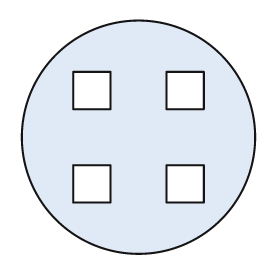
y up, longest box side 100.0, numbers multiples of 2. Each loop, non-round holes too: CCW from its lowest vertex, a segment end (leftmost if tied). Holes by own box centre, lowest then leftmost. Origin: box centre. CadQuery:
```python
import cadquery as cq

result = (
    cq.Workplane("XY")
    .moveTo(0.0, 0.0)
    .circle(50.0)
    .moveTo(-28.0, -28.0)
    .lineTo(-12.0, -28.0)
    .lineTo(-12.0, -12.0)
    .lineTo(-28.0, -12.0)
    .close()
    .moveTo(12.0, -28.0)
    .lineTo(28.0, -28.0)
    .lineTo(28.0, -12.0)
    .lineTo(12.0, -12.0)
    .close()
    .moveTo(-28.0, 12.0)
    .lineTo(-12.0, 12.0)
    .lineTo(-12.0, 28.0)
    .lineTo(-28.0, 28.0)
    .close()
    .moveTo(12.0, 12.0)
    .lineTo(28.0, 12.0)
    .lineTo(28.0, 28.0)
    .lineTo(12.0, 28.0)
    .close()
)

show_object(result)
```